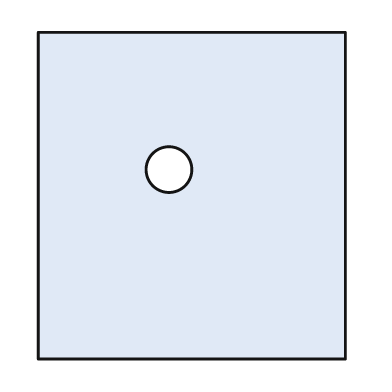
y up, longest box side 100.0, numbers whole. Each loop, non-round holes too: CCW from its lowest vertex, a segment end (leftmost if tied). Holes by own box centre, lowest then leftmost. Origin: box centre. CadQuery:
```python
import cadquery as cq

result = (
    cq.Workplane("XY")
    .moveTo(-47.0, -50.0)
    .lineTo(47.0, -50.0)
    .lineTo(47.0, 50.0)
    .lineTo(-47.0, 50.0)
    .close()
    .moveTo(-7.0, 8.0)
    .circle(7.0)
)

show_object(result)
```